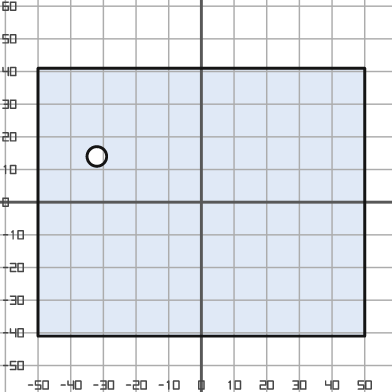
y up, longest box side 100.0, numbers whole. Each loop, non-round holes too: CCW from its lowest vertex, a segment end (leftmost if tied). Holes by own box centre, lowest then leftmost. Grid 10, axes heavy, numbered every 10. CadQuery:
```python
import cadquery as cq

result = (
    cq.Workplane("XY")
    .moveTo(-50.0, -41.0)
    .lineTo(50.0, -41.0)
    .lineTo(50.0, 41.0)
    .lineTo(-50.0, 41.0)
    .close()
    .moveTo(-32.0, 14.0)
    .circle(3.0)
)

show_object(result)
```